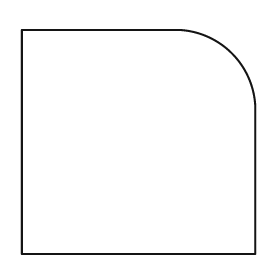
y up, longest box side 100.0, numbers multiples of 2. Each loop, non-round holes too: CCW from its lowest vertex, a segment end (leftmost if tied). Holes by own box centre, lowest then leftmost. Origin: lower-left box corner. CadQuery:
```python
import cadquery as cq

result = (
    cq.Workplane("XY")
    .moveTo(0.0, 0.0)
    .lineTo(100.0, 0.0)
    .lineTo(100.0, 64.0)
    .threePointArc((90.0, 86.0), (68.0, 96.0))
    .lineTo(0.0, 96.0)
    .close()
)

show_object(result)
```